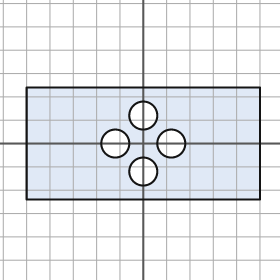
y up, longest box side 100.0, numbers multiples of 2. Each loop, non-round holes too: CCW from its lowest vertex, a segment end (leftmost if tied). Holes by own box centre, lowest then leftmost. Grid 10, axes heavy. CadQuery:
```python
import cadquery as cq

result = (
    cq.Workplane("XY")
    .moveTo(-50.0, -24.0)
    .lineTo(50.0, -24.0)
    .lineTo(50.0, 24.0)
    .lineTo(-50.0, 24.0)
    .close()
    .moveTo(0.0, -12.0)
    .circle(6.0)
    .moveTo(-12.0, 0.0)
    .circle(6.0)
    .moveTo(12.0, 0.0)
    .circle(6.0)
    .moveTo(0.0, 12.0)
    .circle(6.0)
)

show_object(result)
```